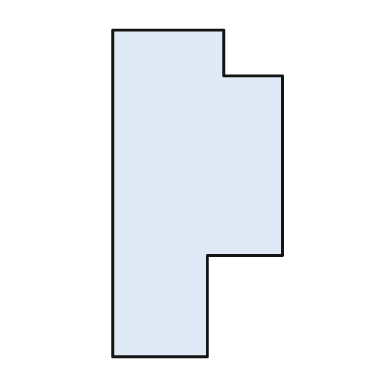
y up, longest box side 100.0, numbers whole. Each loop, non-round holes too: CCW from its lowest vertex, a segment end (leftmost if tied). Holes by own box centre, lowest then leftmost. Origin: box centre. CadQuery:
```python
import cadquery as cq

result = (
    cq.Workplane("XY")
    .moveTo(-26.0, -50.0)
    .lineTo(3.0, -50.0)
    .lineTo(3.0, -19.0)
    .lineTo(26.0, -19.0)
    .lineTo(26.0, 36.0)
    .lineTo(8.0, 36.0)
    .lineTo(8.0, 50.0)
    .lineTo(-26.0, 50.0)
    .close()
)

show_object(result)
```